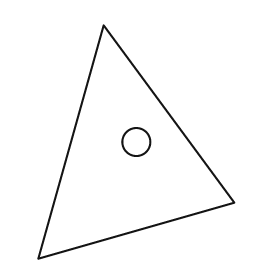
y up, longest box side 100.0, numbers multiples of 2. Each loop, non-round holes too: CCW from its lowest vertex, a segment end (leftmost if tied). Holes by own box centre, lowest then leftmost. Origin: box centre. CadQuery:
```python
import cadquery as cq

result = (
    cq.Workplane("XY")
    .moveTo(-42.0, -50.0)
    .lineTo(42.0, -26.0)
    .lineTo(-14.0, 50.0)
    .close()
    .moveTo(0.0, 0.0)
    .circle(6.0)
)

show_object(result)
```